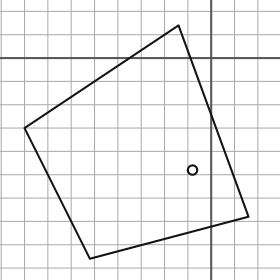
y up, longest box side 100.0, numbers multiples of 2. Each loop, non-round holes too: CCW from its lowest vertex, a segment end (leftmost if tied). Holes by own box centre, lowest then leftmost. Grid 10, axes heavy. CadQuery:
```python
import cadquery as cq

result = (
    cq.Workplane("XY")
    .moveTo(-52.0, -86.0)
    .lineTo(16.0, -68.0)
    .lineTo(-14.0, 14.0)
    .lineTo(-80.0, -30.0)
    .close()
    .moveTo(-8.0, -48.0)
    .circle(2.0)
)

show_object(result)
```